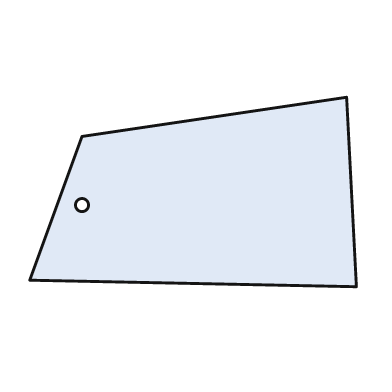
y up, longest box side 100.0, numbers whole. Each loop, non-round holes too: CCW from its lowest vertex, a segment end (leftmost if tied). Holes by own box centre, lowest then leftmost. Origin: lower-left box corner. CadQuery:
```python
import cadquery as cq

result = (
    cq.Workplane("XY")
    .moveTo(100.0, 0.0)
    .lineTo(97.0, 58.0)
    .lineTo(16.0, 46.0)
    .lineTo(0.0, 2.0)
    .close()
    .moveTo(16.0, 25.0)
    .circle(2.0)
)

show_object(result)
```